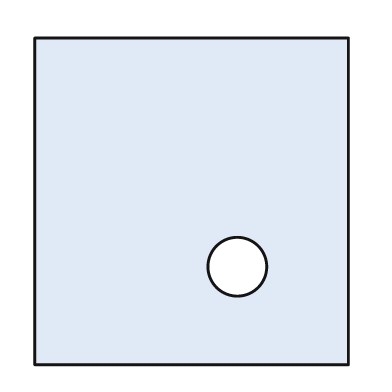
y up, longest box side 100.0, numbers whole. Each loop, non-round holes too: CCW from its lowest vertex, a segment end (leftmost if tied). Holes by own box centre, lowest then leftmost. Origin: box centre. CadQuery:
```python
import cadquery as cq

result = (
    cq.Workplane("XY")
    .moveTo(-48.0, -50.0)
    .lineTo(48.0, -50.0)
    .lineTo(48.0, 50.0)
    .lineTo(-48.0, 50.0)
    .close()
    .moveTo(14.0, -20.0)
    .circle(9.0)
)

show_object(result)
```